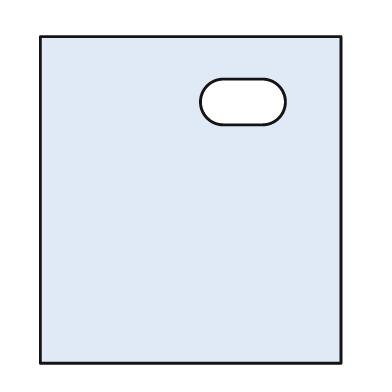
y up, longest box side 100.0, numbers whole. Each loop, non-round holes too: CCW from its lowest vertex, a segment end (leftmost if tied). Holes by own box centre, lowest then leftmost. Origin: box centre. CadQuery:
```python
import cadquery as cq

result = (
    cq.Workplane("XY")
    .moveTo(-46.0, -50.0)
    .lineTo(46.0, -50.0)
    .lineTo(46.0, 50.0)
    .lineTo(-46.0, 50.0)
    .close()
    .moveTo(10.0, 23.0)
    .lineTo(22.0, 23.0)
    .threePointArc((29.0, 30.0), (22.0, 37.0))
    .lineTo(10.0, 37.0)
    .threePointArc((3.0, 30.0), (10.0, 23.0))
    .close()
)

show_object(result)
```